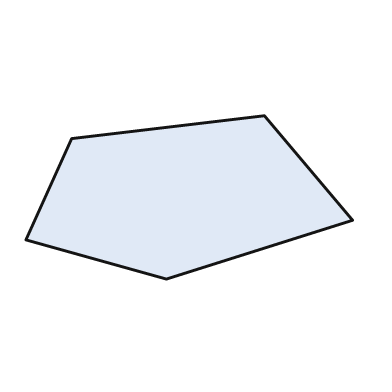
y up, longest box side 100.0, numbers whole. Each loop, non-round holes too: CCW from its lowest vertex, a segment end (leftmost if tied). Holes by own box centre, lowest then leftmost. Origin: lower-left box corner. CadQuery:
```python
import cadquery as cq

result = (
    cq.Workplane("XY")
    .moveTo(43.0, 0.0)
    .lineTo(100.0, 18.0)
    .lineTo(73.0, 50.0)
    .lineTo(14.0, 43.0)
    .lineTo(0.0, 12.0)
    .close()
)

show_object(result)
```